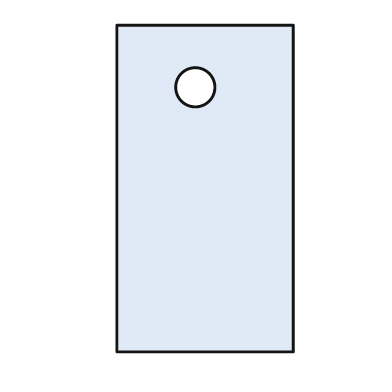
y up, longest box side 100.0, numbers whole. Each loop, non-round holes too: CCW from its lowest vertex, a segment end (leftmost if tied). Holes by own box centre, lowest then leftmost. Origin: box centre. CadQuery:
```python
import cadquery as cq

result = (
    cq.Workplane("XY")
    .moveTo(-27.0, -50.0)
    .lineTo(27.0, -50.0)
    .lineTo(27.0, 50.0)
    .lineTo(-27.0, 50.0)
    .close()
    .moveTo(-3.0, 31.0)
    .circle(6.0)
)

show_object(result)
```